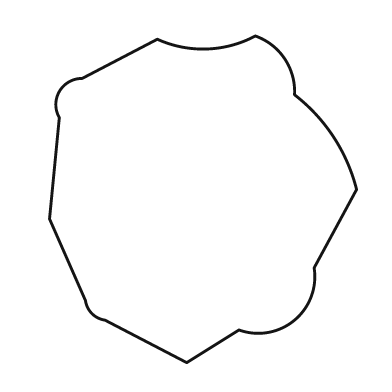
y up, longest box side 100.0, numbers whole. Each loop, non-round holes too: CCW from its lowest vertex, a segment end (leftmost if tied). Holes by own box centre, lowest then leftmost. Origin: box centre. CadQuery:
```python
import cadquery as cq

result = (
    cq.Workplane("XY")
    .moveTo(-5.0, -50.0)
    .lineTo(11.0, -40.0)
    .threePointArc((28.0, -37.0), (34.0, -21.0))
    .lineTo(47.0, 3.0)
    .threePointArc((40.0, 19.0), (28.0, 32.0))
    .threePointArc((25.0, 43.0), (16.0, 50.0))
    .threePointArc((1.0, 46.0), (-14.0, 49.0))
    .lineTo(-37.0, 37.0)
    .threePointArc((-44.0, 33.0), (-44.0, 25.0))
    .lineTo(-47.0, -6.0)
    .lineTo(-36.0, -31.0)
    .threePointArc((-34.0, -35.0), (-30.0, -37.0))
    .close()
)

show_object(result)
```